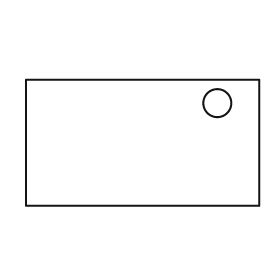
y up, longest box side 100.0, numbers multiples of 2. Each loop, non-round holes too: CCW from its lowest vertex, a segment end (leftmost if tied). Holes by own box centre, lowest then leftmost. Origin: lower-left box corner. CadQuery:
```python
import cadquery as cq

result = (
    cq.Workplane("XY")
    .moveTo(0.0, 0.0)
    .lineTo(100.0, 0.0)
    .lineTo(100.0, 54.0)
    .lineTo(0.0, 54.0)
    .close()
    .moveTo(82.0, 44.0)
    .circle(6.0)
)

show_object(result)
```